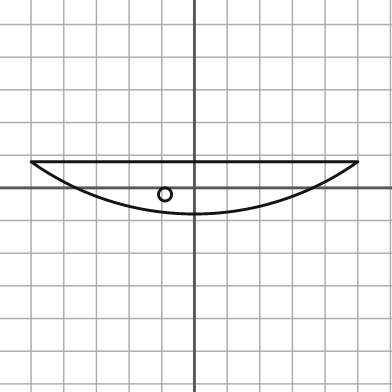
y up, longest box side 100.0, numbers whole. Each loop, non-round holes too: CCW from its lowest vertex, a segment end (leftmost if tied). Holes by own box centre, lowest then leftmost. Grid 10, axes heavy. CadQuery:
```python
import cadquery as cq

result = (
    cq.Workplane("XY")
    .moveTo(-50.0, 8.0)
    .threePointArc((0.0, -8.0), (50.0, 8.0))
    .close()
    .moveTo(-9.0, -2.0)
    .circle(2.0)
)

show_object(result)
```